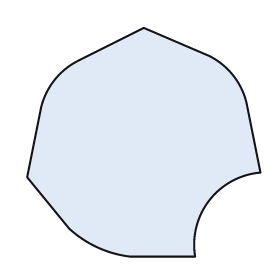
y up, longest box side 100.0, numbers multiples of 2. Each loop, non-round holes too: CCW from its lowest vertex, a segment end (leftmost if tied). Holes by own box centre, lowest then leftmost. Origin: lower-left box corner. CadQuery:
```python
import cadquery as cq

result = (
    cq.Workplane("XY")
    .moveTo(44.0, 0.0)
    .lineTo(72.0, 0.0)
    .threePointArc((78.0, 24.0), (100.0, 36.0))
    .lineTo(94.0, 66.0)
    .threePointArc((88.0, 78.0), (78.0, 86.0))
    .lineTo(50.0, 98.0)
    .lineTo(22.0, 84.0)
    .threePointArc((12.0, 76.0), (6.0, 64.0))
    .lineTo(0.0, 34.0)
    .lineTo(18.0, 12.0)
    .threePointArc((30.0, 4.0), (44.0, 0.0))
    .close()
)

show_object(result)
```